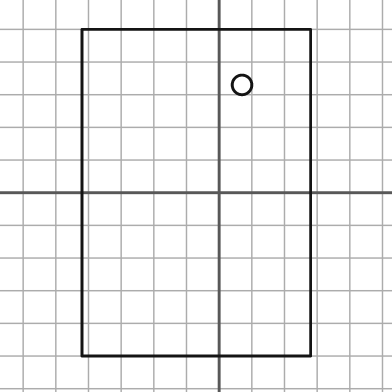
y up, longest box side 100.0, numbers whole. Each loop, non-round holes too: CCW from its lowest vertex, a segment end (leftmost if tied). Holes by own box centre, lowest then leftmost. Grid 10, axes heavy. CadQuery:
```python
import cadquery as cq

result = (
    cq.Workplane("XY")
    .moveTo(-42.0, -50.0)
    .lineTo(28.0, -50.0)
    .lineTo(28.0, 50.0)
    .lineTo(-42.0, 50.0)
    .close()
    .moveTo(7.0, 33.0)
    .circle(3.0)
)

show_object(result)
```